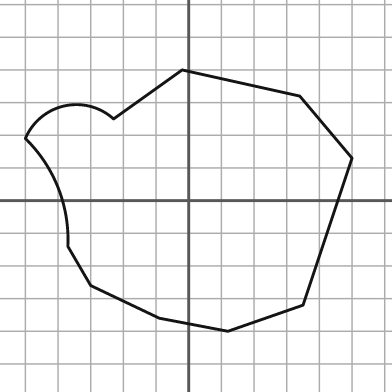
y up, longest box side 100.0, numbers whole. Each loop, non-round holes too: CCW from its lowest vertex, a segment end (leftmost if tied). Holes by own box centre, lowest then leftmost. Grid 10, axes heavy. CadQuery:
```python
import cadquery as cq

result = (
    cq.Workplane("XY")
    .moveTo(12.0, -40.0)
    .lineTo(35.0, -32.0)
    .lineTo(50.0, 13.0)
    .lineTo(34.0, 32.0)
    .lineTo(-2.0, 40.0)
    .lineTo(-23.0, 25.0)
    .threePointArc((-38.0, 29.0), (-50.0, 19.0))
    .threePointArc((-40.0, 4.0), (-37.0, -14.0))
    .lineTo(-30.0, -26.0)
    .lineTo(-9.0, -36.0)
    .close()
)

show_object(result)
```